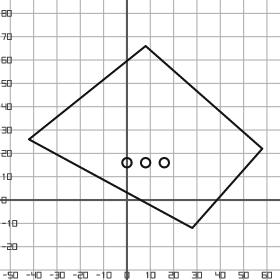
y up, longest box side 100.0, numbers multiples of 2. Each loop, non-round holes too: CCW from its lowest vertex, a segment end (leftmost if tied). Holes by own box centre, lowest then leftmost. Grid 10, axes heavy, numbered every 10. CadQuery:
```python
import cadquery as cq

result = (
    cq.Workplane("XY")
    .moveTo(28.0, -12.0)
    .lineTo(58.0, 22.0)
    .lineTo(8.0, 66.0)
    .lineTo(-42.0, 26.0)
    .close()
    .moveTo(0.0, 16.0)
    .circle(2.0)
    .moveTo(8.0, 16.0)
    .circle(2.0)
    .moveTo(16.0, 16.0)
    .circle(2.0)
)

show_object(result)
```